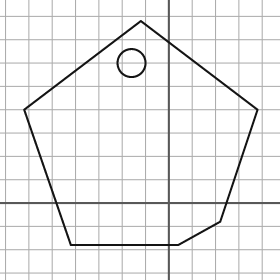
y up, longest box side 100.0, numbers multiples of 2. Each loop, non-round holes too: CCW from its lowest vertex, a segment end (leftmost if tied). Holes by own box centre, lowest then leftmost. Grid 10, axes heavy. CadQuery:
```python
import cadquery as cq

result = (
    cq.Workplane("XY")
    .moveTo(-42.0, -18.0)
    .lineTo(4.0, -18.0)
    .lineTo(22.0, -8.0)
    .lineTo(38.0, 40.0)
    .lineTo(-12.0, 78.0)
    .lineTo(-62.0, 40.0)
    .close()
    .moveTo(-16.0, 60.0)
    .circle(6.0)
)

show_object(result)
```